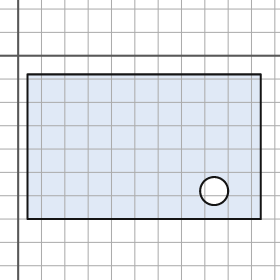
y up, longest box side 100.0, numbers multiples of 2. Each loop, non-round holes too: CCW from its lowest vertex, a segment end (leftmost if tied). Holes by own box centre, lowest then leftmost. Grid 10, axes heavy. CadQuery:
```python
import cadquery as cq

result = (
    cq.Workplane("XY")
    .moveTo(4.0, -70.0)
    .lineTo(104.0, -70.0)
    .lineTo(104.0, -8.0)
    .lineTo(4.0, -8.0)
    .close()
    .moveTo(84.0, -58.0)
    .circle(6.0)
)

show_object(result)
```